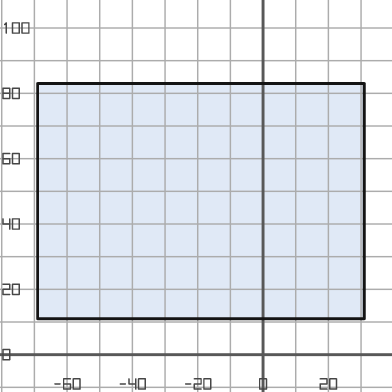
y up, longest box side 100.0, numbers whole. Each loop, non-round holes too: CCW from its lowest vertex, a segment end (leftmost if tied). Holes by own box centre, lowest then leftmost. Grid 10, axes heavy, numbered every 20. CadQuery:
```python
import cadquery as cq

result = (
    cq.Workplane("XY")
    .moveTo(-69.0, 11.0)
    .lineTo(31.0, 11.0)
    .lineTo(31.0, 83.0)
    .lineTo(-69.0, 83.0)
    .close()
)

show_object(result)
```